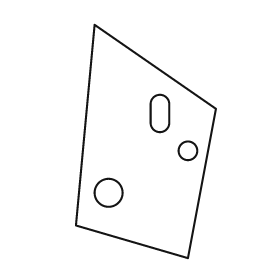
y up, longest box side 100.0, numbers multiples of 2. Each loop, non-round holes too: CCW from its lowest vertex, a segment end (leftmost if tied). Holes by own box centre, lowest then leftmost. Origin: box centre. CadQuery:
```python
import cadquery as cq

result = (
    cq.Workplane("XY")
    .moveTo(18.0, -50.0)
    .lineTo(30.0, 14.0)
    .lineTo(-22.0, 50.0)
    .lineTo(-30.0, -36.0)
    .close()
    .moveTo(-16.0, -22.0)
    .circle(6.0)
    .moveTo(18.0, -4.0)
    .circle(4.0)
    .moveTo(2.0, 8.0)
    .threePointArc((6.0, 4.0), (10.0, 8.0))
    .lineTo(10.0, 16.0)
    .threePointArc((6.0, 20.0), (2.0, 16.0))
    .close()
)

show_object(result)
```